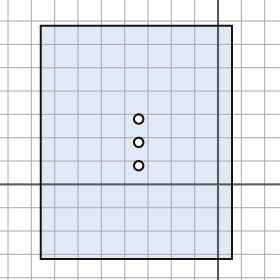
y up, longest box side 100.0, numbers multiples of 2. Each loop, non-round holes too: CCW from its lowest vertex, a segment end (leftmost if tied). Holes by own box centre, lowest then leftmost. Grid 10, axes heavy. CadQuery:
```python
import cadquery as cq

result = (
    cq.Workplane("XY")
    .moveTo(-76.0, -32.0)
    .lineTo(6.0, -32.0)
    .lineTo(6.0, 68.0)
    .lineTo(-76.0, 68.0)
    .close()
    .moveTo(-34.0, 8.0)
    .circle(2.0)
    .moveTo(-34.0, 18.0)
    .circle(2.0)
    .moveTo(-34.0, 28.0)
    .circle(2.0)
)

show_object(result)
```